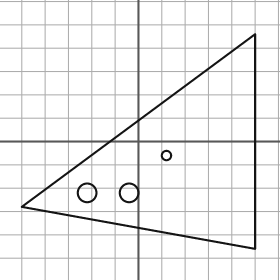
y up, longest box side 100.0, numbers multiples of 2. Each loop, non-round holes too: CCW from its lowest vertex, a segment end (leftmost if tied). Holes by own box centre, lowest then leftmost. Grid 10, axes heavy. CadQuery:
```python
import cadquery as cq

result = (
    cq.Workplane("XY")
    .moveTo(50.0, -46.0)
    .lineTo(50.0, 46.0)
    .lineTo(-50.0, -28.0)
    .close()
    .moveTo(-22.0, -22.0)
    .circle(4.0)
    .moveTo(-4.0, -22.0)
    .circle(4.0)
    .moveTo(12.0, -6.0)
    .circle(2.0)
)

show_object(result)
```